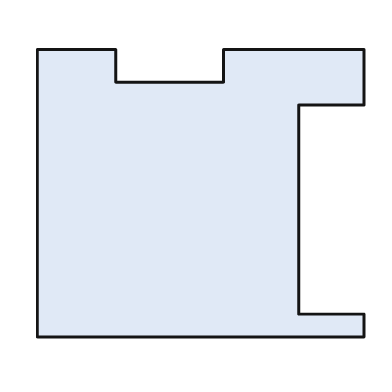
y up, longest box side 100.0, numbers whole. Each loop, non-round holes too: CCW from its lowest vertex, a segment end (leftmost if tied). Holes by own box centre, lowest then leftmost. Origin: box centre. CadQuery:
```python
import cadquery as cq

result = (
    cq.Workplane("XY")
    .moveTo(-50.0, -44.0)
    .lineTo(50.0, -44.0)
    .lineTo(50.0, -37.0)
    .lineTo(30.0, -37.0)
    .lineTo(30.0, 27.0)
    .lineTo(50.0, 27.0)
    .lineTo(50.0, 44.0)
    .lineTo(7.0, 44.0)
    .lineTo(7.0, 34.0)
    .lineTo(-26.0, 34.0)
    .lineTo(-26.0, 44.0)
    .lineTo(-50.0, 44.0)
    .close()
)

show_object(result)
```